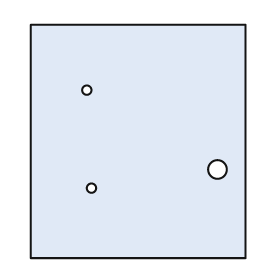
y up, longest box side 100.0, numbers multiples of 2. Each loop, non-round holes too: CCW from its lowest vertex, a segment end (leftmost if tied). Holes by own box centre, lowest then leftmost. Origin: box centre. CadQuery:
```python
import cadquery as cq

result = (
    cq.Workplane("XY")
    .moveTo(-46.0, -50.0)
    .lineTo(46.0, -50.0)
    .lineTo(46.0, 50.0)
    .lineTo(-46.0, 50.0)
    .close()
    .moveTo(-20.0, -20.0)
    .circle(2.0)
    .moveTo(34.0, -12.0)
    .circle(4.0)
    .moveTo(-22.0, 22.0)
    .circle(2.0)
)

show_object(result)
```